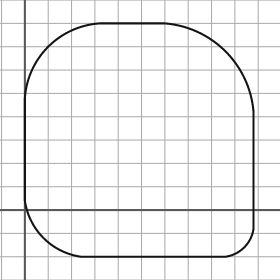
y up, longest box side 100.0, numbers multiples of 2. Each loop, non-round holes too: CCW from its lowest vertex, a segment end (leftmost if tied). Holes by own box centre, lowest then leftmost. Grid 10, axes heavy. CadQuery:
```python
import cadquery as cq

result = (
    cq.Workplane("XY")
    .moveTo(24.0, -20.0)
    .lineTo(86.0, -20.0)
    .threePointArc((94.0, -16.0), (98.0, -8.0))
    .lineTo(98.0, 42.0)
    .threePointArc((86.0, 68.0), (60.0, 80.0))
    .lineTo(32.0, 80.0)
    .threePointArc((10.0, 70.0), (0.0, 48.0))
    .lineTo(0.0, 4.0)
    .threePointArc((8.0, -12.0), (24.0, -20.0))
    .close()
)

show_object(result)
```